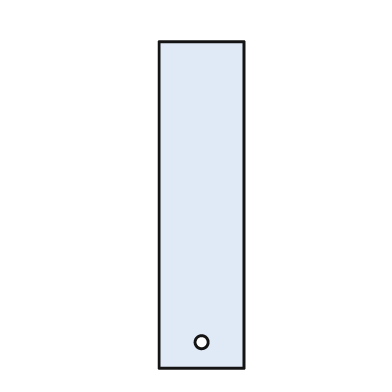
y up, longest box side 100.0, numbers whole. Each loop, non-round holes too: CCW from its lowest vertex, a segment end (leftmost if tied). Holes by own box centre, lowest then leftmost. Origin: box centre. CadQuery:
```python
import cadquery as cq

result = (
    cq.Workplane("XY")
    .moveTo(-13.0, -50.0)
    .lineTo(13.0, -50.0)
    .lineTo(13.0, 50.0)
    .lineTo(-13.0, 50.0)
    .close()
    .moveTo(0.0, -42.0)
    .circle(2.0)
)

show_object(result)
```